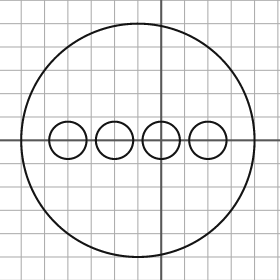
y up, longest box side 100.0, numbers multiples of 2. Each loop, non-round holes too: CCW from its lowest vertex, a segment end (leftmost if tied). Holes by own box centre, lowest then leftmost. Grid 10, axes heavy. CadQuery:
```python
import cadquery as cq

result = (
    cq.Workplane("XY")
    .moveTo(-10.0, 0.0)
    .circle(50.0)
    .moveTo(-40.0, 0.0)
    .circle(8.0)
    .moveTo(-20.0, 0.0)
    .circle(8.0)
    .moveTo(0.0, 0.0)
    .circle(8.0)
    .moveTo(20.0, 0.0)
    .circle(8.0)
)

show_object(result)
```